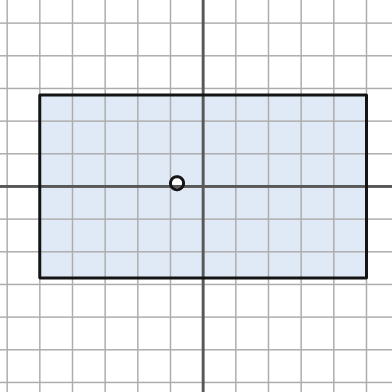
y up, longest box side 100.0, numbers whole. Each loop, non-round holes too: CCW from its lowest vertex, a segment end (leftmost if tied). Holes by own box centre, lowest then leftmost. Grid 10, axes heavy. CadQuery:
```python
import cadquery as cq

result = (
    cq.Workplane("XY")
    .moveTo(-50.0, -28.0)
    .lineTo(50.0, -28.0)
    .lineTo(50.0, 28.0)
    .lineTo(-50.0, 28.0)
    .close()
    .moveTo(-8.0, 1.0)
    .circle(2.0)
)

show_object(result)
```